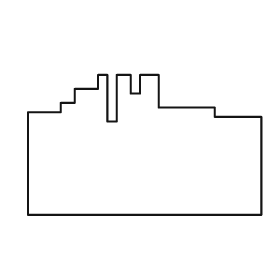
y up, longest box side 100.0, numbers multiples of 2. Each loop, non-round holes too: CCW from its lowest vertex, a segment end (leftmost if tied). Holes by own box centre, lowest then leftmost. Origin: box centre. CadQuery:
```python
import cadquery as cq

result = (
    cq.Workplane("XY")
    .moveTo(-50.0, -30.0)
    .lineTo(50.0, -30.0)
    .lineTo(50.0, 12.0)
    .lineTo(30.0, 12.0)
    .lineTo(30.0, 16.0)
    .lineTo(6.0, 16.0)
    .lineTo(6.0, 30.0)
    .lineTo(-2.0, 30.0)
    .lineTo(-2.0, 22.0)
    .lineTo(-6.0, 22.0)
    .lineTo(-6.0, 30.0)
    .lineTo(-12.0, 30.0)
    .lineTo(-12.0, 10.0)
    .lineTo(-16.0, 10.0)
    .lineTo(-16.0, 30.0)
    .lineTo(-20.0, 30.0)
    .lineTo(-20.0, 24.0)
    .lineTo(-30.0, 24.0)
    .lineTo(-30.0, 18.0)
    .lineTo(-36.0, 18.0)
    .lineTo(-36.0, 14.0)
    .lineTo(-50.0, 14.0)
    .close()
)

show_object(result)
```